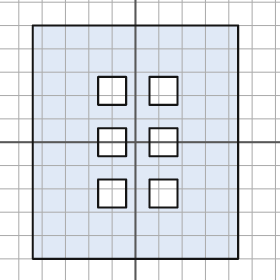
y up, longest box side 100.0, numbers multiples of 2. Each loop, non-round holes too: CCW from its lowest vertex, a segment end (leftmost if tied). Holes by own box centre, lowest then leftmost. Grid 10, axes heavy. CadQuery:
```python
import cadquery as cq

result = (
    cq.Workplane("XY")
    .moveTo(-44.0, -50.0)
    .lineTo(44.0, -50.0)
    .lineTo(44.0, 50.0)
    .lineTo(-44.0, 50.0)
    .close()
    .moveTo(-16.0, -28.0)
    .lineTo(-4.0, -28.0)
    .lineTo(-4.0, -16.0)
    .lineTo(-16.0, -16.0)
    .close()
    .moveTo(6.0, -28.0)
    .lineTo(18.0, -28.0)
    .lineTo(18.0, -16.0)
    .lineTo(6.0, -16.0)
    .close()
    .moveTo(-16.0, -6.0)
    .lineTo(-4.0, -6.0)
    .lineTo(-4.0, 6.0)
    .lineTo(-16.0, 6.0)
    .close()
    .moveTo(6.0, -6.0)
    .lineTo(18.0, -6.0)
    .lineTo(18.0, 6.0)
    .lineTo(6.0, 6.0)
    .close()
    .moveTo(-16.0, 16.0)
    .lineTo(-4.0, 16.0)
    .lineTo(-4.0, 28.0)
    .lineTo(-16.0, 28.0)
    .close()
    .moveTo(6.0, 16.0)
    .lineTo(18.0, 16.0)
    .lineTo(18.0, 28.0)
    .lineTo(6.0, 28.0)
    .close()
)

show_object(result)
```